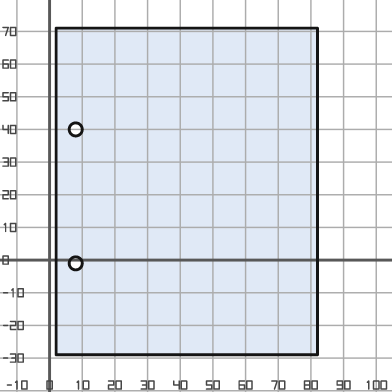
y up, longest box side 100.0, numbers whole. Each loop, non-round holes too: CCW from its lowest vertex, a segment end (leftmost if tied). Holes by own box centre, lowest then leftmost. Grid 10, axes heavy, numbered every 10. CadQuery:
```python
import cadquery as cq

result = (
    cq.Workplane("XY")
    .moveTo(2.0, -29.0)
    .lineTo(82.0, -29.0)
    .lineTo(82.0, 71.0)
    .lineTo(2.0, 71.0)
    .close()
    .moveTo(8.0, -1.0)
    .circle(2.0)
    .moveTo(8.0, 40.0)
    .circle(2.0)
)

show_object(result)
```